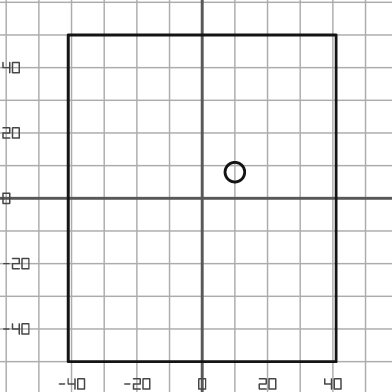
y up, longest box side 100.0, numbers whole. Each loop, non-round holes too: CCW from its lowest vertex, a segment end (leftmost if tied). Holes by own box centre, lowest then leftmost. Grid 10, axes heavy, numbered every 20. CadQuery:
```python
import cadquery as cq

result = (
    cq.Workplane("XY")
    .moveTo(-41.0, -50.0)
    .lineTo(41.0, -50.0)
    .lineTo(41.0, 50.0)
    .lineTo(-41.0, 50.0)
    .close()
    .moveTo(10.0, 8.0)
    .circle(3.0)
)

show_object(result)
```